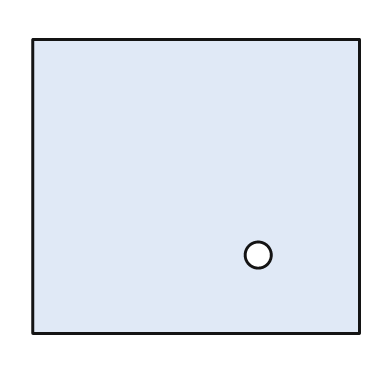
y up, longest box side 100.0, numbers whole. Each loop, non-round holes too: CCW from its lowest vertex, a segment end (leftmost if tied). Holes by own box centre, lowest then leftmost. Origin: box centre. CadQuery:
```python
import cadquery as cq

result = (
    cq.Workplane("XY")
    .moveTo(-50.0, -45.0)
    .lineTo(50.0, -45.0)
    .lineTo(50.0, 45.0)
    .lineTo(-50.0, 45.0)
    .close()
    .moveTo(19.0, -21.0)
    .circle(4.0)
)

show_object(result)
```